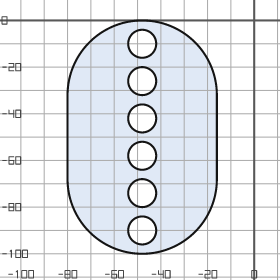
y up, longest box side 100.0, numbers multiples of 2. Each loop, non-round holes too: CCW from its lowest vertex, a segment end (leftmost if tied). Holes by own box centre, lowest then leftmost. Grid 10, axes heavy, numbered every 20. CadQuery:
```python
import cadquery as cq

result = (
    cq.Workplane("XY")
    .moveTo(-80.0, -68.0)
    .threePointArc((-48.0, -100.0), (-16.0, -68.0))
    .lineTo(-16.0, -32.0)
    .threePointArc((-48.0, 0.0), (-80.0, -32.0))
    .close()
    .moveTo(-48.0, -90.0)
    .circle(6.0)
    .moveTo(-48.0, -74.0)
    .circle(6.0)
    .moveTo(-48.0, -58.0)
    .circle(6.0)
    .moveTo(-48.0, -42.0)
    .circle(6.0)
    .moveTo(-48.0, -26.0)
    .circle(6.0)
    .moveTo(-48.0, -10.0)
    .circle(6.0)
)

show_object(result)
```